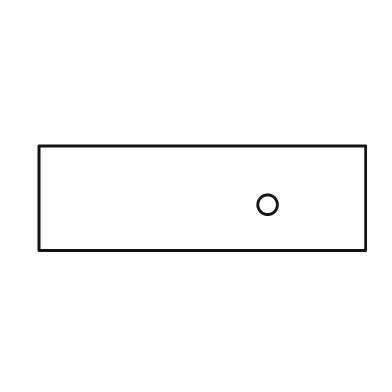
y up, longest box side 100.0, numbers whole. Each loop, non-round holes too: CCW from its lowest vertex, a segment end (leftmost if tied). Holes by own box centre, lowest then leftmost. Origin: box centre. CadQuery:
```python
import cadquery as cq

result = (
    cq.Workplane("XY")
    .moveTo(-50.0, -16.0)
    .lineTo(50.0, -16.0)
    .lineTo(50.0, 16.0)
    .lineTo(-50.0, 16.0)
    .close()
    .moveTo(20.0, -2.0)
    .circle(3.0)
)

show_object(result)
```